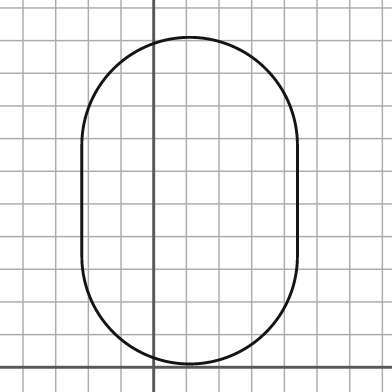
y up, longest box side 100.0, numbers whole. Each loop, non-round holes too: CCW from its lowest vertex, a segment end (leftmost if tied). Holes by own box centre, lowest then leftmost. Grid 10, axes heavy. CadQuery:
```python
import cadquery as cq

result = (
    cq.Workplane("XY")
    .moveTo(-22.0, 34.0)
    .threePointArc((11.0, 1.0), (44.0, 34.0))
    .lineTo(44.0, 68.0)
    .threePointArc((11.0, 101.0), (-22.0, 68.0))
    .close()
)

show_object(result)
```